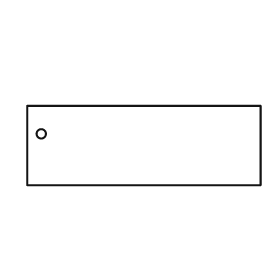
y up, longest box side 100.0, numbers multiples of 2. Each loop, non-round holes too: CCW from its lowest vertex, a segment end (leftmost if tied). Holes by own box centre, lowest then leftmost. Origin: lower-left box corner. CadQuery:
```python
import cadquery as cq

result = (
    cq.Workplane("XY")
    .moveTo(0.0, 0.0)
    .lineTo(100.0, 0.0)
    .lineTo(100.0, 34.0)
    .lineTo(0.0, 34.0)
    .close()
    .moveTo(6.0, 22.0)
    .circle(2.0)
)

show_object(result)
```